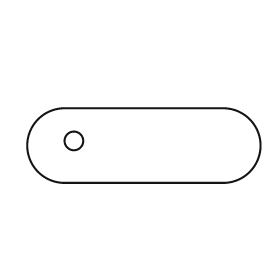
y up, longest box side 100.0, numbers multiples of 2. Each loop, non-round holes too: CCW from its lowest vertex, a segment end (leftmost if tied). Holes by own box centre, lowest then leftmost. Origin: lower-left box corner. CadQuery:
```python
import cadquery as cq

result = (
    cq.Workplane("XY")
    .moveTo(16.0, 0.0)
    .lineTo(84.0, 0.0)
    .threePointArc((100.0, 16.0), (84.0, 32.0))
    .lineTo(16.0, 32.0)
    .threePointArc((0.0, 16.0), (16.0, 0.0))
    .close()
    .moveTo(20.0, 18.0)
    .circle(4.0)
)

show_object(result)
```